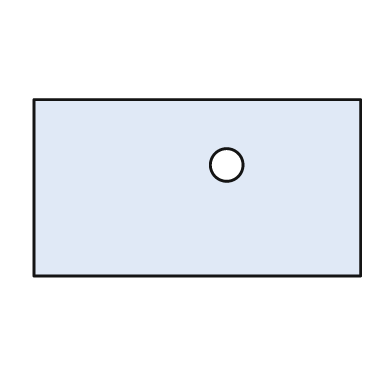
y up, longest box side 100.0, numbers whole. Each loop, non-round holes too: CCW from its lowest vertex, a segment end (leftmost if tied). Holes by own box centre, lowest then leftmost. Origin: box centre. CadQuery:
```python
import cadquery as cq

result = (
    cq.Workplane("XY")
    .moveTo(-50.0, -27.0)
    .lineTo(50.0, -27.0)
    .lineTo(50.0, 27.0)
    .lineTo(-50.0, 27.0)
    .close()
    .moveTo(9.0, 7.0)
    .circle(5.0)
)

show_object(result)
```